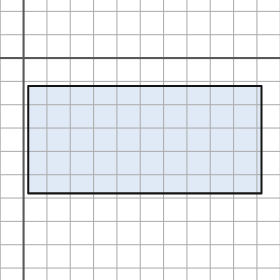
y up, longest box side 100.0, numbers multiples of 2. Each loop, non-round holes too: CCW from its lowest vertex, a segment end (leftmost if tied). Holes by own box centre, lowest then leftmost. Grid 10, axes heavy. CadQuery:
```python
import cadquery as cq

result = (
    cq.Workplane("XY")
    .moveTo(2.0, -58.0)
    .lineTo(102.0, -58.0)
    .lineTo(102.0, -12.0)
    .lineTo(2.0, -12.0)
    .close()
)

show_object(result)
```